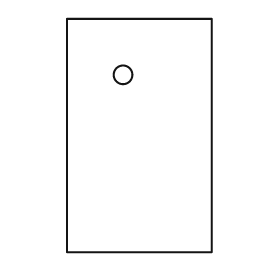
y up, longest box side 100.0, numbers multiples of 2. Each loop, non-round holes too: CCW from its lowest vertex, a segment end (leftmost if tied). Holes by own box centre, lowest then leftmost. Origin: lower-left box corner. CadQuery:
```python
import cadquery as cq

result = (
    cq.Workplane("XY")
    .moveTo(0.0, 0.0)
    .lineTo(62.0, 0.0)
    .lineTo(62.0, 100.0)
    .lineTo(0.0, 100.0)
    .close()
    .moveTo(24.0, 76.0)
    .circle(4.0)
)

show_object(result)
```